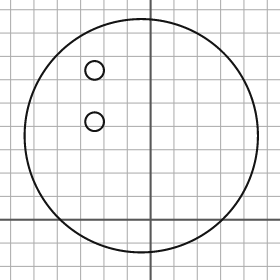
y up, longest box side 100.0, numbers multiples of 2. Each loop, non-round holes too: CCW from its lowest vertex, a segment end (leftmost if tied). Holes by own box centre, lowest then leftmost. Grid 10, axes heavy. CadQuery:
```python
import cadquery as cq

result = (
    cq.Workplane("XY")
    .moveTo(-4.0, 36.0)
    .circle(50.0)
    .moveTo(-24.0, 42.0)
    .circle(4.0)
    .moveTo(-24.0, 64.0)
    .circle(4.0)
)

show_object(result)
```